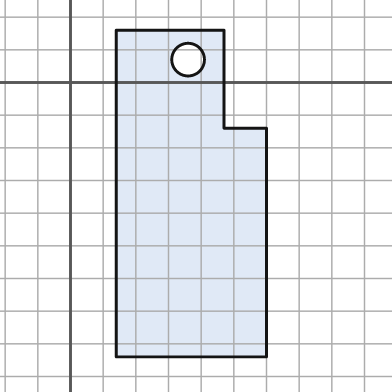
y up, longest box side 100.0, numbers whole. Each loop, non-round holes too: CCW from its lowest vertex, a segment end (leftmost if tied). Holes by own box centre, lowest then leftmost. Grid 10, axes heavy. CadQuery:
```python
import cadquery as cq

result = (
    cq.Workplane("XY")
    .moveTo(14.0, -84.0)
    .lineTo(60.0, -84.0)
    .lineTo(60.0, -14.0)
    .lineTo(47.0, -14.0)
    .lineTo(47.0, 16.0)
    .lineTo(14.0, 16.0)
    .close()
    .moveTo(36.0, 7.0)
    .circle(5.0)
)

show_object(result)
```